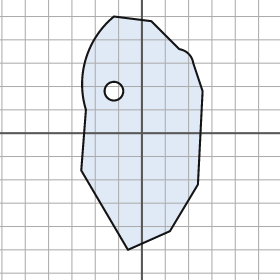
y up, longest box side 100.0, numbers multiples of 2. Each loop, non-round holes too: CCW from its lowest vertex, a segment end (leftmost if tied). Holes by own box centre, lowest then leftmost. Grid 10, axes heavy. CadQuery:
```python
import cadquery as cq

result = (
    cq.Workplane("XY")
    .moveTo(-6.0, -50.0)
    .lineTo(12.0, -42.0)
    .lineTo(24.0, -22.0)
    .lineTo(26.0, 18.0)
    .lineTo(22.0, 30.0)
    .threePointArc((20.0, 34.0), (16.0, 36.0))
    .lineTo(4.0, 48.0)
    .lineTo(-12.0, 50.0)
    .threePointArc((-24.0, 32.0), (-24.0, 10.0))
    .lineTo(-26.0, -16.0)
    .close()
    .moveTo(-12.0, 18.0)
    .circle(4.0)
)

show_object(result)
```